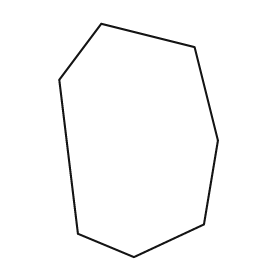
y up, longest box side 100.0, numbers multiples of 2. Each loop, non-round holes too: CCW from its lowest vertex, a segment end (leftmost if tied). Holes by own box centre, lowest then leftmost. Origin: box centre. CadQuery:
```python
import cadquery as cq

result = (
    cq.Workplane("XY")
    .moveTo(-2.0, -50.0)
    .lineTo(28.0, -36.0)
    .lineTo(34.0, 0.0)
    .lineTo(24.0, 40.0)
    .lineTo(-16.0, 50.0)
    .lineTo(-34.0, 26.0)
    .lineTo(-26.0, -40.0)
    .close()
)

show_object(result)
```